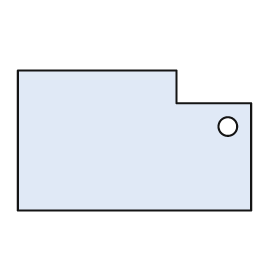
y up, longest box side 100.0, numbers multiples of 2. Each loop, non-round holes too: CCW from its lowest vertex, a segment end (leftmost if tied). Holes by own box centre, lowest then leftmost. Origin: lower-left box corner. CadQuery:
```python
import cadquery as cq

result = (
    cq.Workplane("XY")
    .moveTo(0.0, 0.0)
    .lineTo(100.0, 0.0)
    .lineTo(100.0, 46.0)
    .lineTo(68.0, 46.0)
    .lineTo(68.0, 60.0)
    .lineTo(0.0, 60.0)
    .close()
    .moveTo(90.0, 36.0)
    .circle(4.0)
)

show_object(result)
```